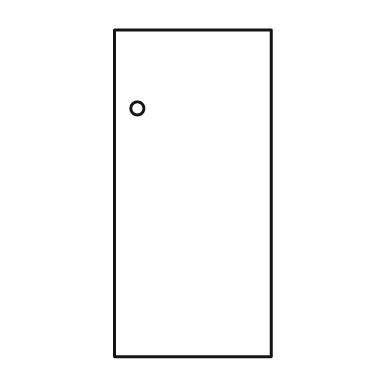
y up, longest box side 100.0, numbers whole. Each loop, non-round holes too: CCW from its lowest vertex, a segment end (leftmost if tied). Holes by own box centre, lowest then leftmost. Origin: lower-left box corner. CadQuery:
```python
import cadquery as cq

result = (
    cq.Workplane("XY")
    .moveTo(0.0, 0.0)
    .lineTo(48.0, 0.0)
    .lineTo(48.0, 100.0)
    .lineTo(0.0, 100.0)
    .close()
    .moveTo(7.0, 76.0)
    .circle(2.0)
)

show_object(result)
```